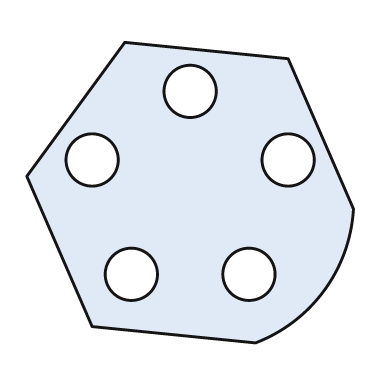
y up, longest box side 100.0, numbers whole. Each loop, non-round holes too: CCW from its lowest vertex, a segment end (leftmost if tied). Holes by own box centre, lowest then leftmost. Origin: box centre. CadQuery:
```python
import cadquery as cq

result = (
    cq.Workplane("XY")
    .moveTo(20.0, -46.0)
    .threePointArc((41.0, -30.0), (50.0, -5.0))
    .lineTo(30.0, 41.0)
    .lineTo(-20.0, 46.0)
    .lineTo(-50.0, 5.0)
    .lineTo(-30.0, -41.0)
    .close()
    .moveTo(-18.0, -25.0)
    .circle(8.0)
    .moveTo(18.0, -25.0)
    .circle(8.0)
    .moveTo(-30.0, 10.0)
    .circle(8.0)
    .moveTo(30.0, 10.0)
    .circle(8.0)
    .moveTo(0.0, 31.0)
    .circle(8.0)
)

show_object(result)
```